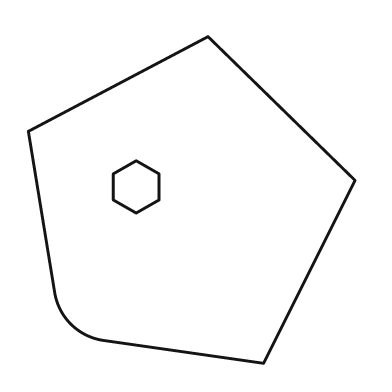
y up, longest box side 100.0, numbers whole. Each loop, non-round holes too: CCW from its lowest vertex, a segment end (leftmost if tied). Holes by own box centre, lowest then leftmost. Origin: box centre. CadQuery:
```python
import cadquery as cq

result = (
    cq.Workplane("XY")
    .moveTo(22.0, -50.0)
    .lineTo(50.0, 6.0)
    .lineTo(5.0, 50.0)
    .lineTo(-50.0, 21.0)
    .lineTo(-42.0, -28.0)
    .threePointArc((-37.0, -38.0), (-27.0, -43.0))
    .close()
    .moveTo(-17.0, -4.0)
    .lineTo(-10.0, 0.0)
    .lineTo(-10.0, 8.0)
    .lineTo(-17.0, 12.0)
    .lineTo(-24.0, 8.0)
    .lineTo(-24.0, 0.0)
    .close()
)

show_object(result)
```